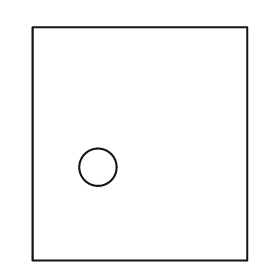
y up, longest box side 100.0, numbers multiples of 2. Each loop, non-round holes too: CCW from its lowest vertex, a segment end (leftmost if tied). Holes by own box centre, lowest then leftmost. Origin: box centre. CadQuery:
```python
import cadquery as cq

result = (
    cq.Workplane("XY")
    .moveTo(-46.0, -50.0)
    .lineTo(46.0, -50.0)
    .lineTo(46.0, 50.0)
    .lineTo(-46.0, 50.0)
    .close()
    .moveTo(-18.0, -10.0)
    .circle(8.0)
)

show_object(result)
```